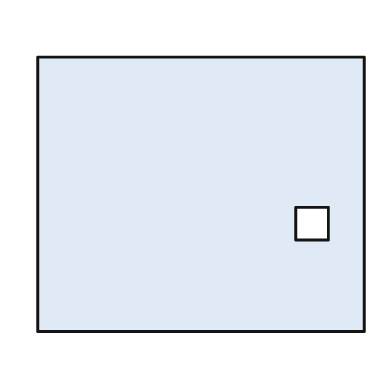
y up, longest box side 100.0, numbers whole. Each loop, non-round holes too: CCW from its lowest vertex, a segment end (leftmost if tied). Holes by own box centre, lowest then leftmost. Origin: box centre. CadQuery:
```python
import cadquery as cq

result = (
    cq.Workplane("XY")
    .moveTo(-50.0, -42.0)
    .lineTo(50.0, -42.0)
    .lineTo(50.0, 42.0)
    .lineTo(-50.0, 42.0)
    .close()
    .moveTo(29.0, -14.0)
    .lineTo(39.0, -14.0)
    .lineTo(39.0, -4.0)
    .lineTo(29.0, -4.0)
    .close()
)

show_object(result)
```